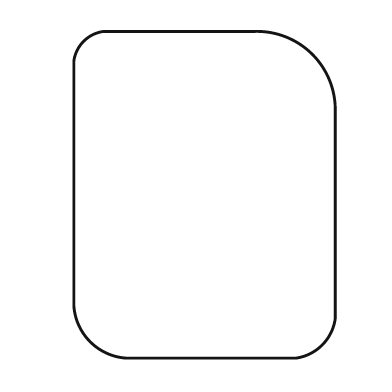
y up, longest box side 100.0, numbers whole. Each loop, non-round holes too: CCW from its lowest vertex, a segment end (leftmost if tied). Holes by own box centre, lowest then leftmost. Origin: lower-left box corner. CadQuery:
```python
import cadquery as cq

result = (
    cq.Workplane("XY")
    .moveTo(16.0, 0.0)
    .lineTo(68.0, 0.0)
    .threePointArc((76.0, 4.0), (80.0, 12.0))
    .lineTo(80.0, 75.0)
    .threePointArc((73.0, 93.0), (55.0, 100.0))
    .lineTo(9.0, 100.0)
    .threePointArc((3.0, 97.0), (0.0, 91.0))
    .lineTo(0.0, 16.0)
    .threePointArc((5.0, 5.0), (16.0, 0.0))
    .close()
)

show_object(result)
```